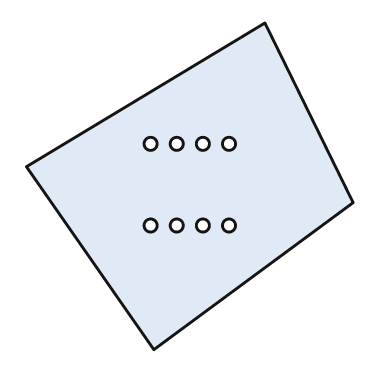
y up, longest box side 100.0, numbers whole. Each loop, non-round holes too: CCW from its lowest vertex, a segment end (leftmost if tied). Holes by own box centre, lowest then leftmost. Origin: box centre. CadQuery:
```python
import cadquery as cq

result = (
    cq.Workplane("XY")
    .moveTo(-11.0, -50.0)
    .lineTo(50.0, -5.0)
    .lineTo(23.0, 50.0)
    .lineTo(-50.0, 6.0)
    .close()
    .moveTo(-12.0, -12.0)
    .circle(2.0)
    .moveTo(-4.0, -12.0)
    .circle(2.0)
    .moveTo(4.0, -12.0)
    .circle(2.0)
    .moveTo(12.0, -12.0)
    .circle(2.0)
    .moveTo(-12.0, 13.0)
    .circle(2.0)
    .moveTo(-4.0, 13.0)
    .circle(2.0)
    .moveTo(4.0, 13.0)
    .circle(2.0)
    .moveTo(12.0, 13.0)
    .circle(2.0)
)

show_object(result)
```